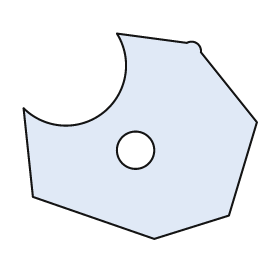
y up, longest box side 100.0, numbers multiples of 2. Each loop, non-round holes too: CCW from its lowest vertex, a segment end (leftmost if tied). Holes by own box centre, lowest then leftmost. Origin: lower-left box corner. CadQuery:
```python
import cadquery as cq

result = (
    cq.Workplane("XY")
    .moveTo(56.0, 0.0)
    .lineTo(88.0, 10.0)
    .lineTo(100.0, 50.0)
    .lineTo(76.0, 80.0)
    .threePointArc((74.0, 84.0), (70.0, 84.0))
    .lineTo(40.0, 88.0)
    .threePointArc((34.0, 54.0), (0.0, 56.0))
    .lineTo(4.0, 18.0)
    .close()
    .moveTo(48.0, 38.0)
    .circle(8.0)
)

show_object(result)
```